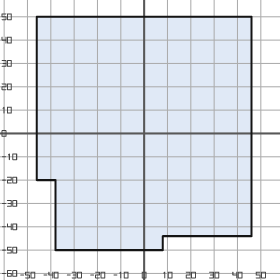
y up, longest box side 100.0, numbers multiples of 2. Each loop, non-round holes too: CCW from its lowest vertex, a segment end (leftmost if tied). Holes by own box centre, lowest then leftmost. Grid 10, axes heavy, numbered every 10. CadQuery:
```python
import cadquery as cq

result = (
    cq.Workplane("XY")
    .moveTo(-38.0, -50.0)
    .lineTo(8.0, -50.0)
    .lineTo(8.0, -44.0)
    .lineTo(46.0, -44.0)
    .lineTo(46.0, 50.0)
    .lineTo(-46.0, 50.0)
    .lineTo(-46.0, -20.0)
    .lineTo(-38.0, -20.0)
    .close()
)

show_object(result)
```